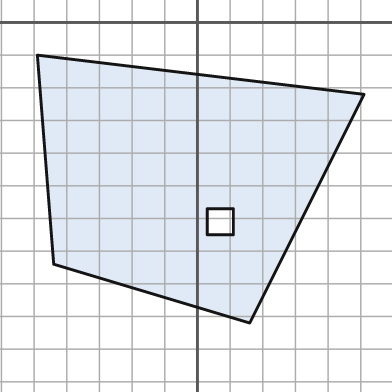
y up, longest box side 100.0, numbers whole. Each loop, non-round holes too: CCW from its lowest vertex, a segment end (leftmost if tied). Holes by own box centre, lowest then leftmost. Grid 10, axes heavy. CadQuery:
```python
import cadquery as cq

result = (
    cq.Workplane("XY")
    .moveTo(16.0, -92.0)
    .lineTo(51.0, -22.0)
    .lineTo(-49.0, -10.0)
    .lineTo(-44.0, -74.0)
    .close()
    .moveTo(3.0, -65.0)
    .lineTo(11.0, -65.0)
    .lineTo(11.0, -57.0)
    .lineTo(3.0, -57.0)
    .close()
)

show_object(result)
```